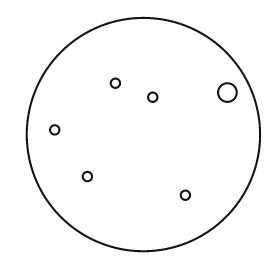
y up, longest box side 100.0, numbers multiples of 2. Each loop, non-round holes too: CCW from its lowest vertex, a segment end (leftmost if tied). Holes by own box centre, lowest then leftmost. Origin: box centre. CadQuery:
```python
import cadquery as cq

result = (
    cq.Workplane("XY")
    .moveTo(0.0, 0.0)
    .circle(50.0)
    .moveTo(18.0, -26.0)
    .circle(2.0)
    .moveTo(-24.0, -18.0)
    .circle(2.0)
    .moveTo(-38.0, 2.0)
    .circle(2.0)
    .moveTo(4.0, 16.0)
    .circle(2.0)
    .moveTo(36.0, 18.0)
    .circle(4.0)
    .moveTo(-12.0, 22.0)
    .circle(2.0)
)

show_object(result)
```